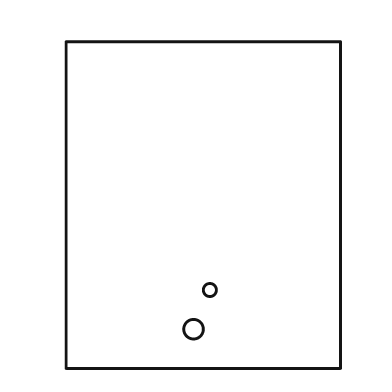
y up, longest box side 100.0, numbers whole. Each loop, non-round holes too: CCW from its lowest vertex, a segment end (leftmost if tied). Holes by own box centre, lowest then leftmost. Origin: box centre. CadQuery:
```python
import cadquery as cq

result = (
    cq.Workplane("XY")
    .moveTo(-42.0, -50.0)
    .lineTo(42.0, -50.0)
    .lineTo(42.0, 50.0)
    .lineTo(-42.0, 50.0)
    .close()
    .moveTo(-3.0, -38.0)
    .circle(3.0)
    .moveTo(2.0, -26.0)
    .circle(2.0)
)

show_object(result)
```